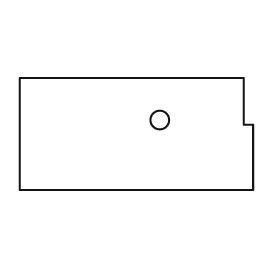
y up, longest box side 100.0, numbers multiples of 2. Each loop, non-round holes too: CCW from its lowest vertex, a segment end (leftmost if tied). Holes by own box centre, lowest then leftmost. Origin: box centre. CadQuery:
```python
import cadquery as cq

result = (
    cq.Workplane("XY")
    .moveTo(-50.0, -24.0)
    .lineTo(50.0, -24.0)
    .lineTo(50.0, 4.0)
    .lineTo(46.0, 4.0)
    .lineTo(46.0, 24.0)
    .lineTo(-50.0, 24.0)
    .close()
    .moveTo(10.0, 6.0)
    .circle(4.0)
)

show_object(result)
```